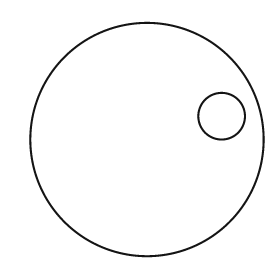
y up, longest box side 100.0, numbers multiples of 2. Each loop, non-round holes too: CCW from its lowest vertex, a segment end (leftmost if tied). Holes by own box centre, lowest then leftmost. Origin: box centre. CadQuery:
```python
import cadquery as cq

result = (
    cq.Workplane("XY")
    .moveTo(0.0, 0.0)
    .circle(50.0)
    .moveTo(32.0, 10.0)
    .circle(10.0)
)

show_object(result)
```